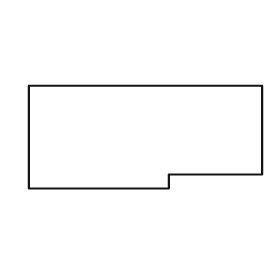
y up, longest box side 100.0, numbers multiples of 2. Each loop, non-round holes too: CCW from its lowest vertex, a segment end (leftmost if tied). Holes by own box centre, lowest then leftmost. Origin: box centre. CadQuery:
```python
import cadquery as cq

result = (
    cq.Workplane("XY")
    .moveTo(-50.0, -22.0)
    .lineTo(10.0, -22.0)
    .lineTo(10.0, -16.0)
    .lineTo(50.0, -16.0)
    .lineTo(50.0, 22.0)
    .lineTo(-50.0, 22.0)
    .close()
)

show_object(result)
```